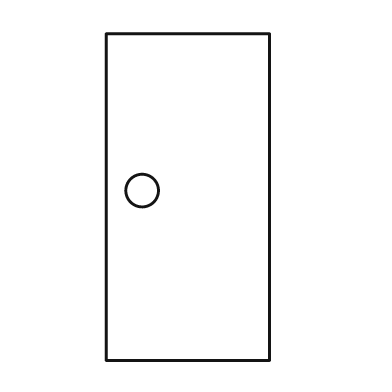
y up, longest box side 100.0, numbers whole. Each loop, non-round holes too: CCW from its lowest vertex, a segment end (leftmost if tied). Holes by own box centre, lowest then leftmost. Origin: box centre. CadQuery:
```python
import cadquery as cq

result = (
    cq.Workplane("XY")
    .moveTo(-25.0, -50.0)
    .lineTo(25.0, -50.0)
    .lineTo(25.0, 50.0)
    .lineTo(-25.0, 50.0)
    .close()
    .moveTo(-14.0, 2.0)
    .circle(5.0)
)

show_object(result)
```